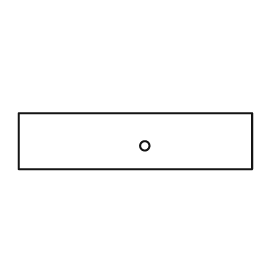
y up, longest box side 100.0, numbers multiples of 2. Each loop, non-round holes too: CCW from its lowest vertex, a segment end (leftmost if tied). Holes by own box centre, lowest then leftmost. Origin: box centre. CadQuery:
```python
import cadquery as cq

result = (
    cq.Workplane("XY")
    .moveTo(-50.0, -12.0)
    .lineTo(50.0, -12.0)
    .lineTo(50.0, 12.0)
    .lineTo(-50.0, 12.0)
    .close()
    .moveTo(4.0, -2.0)
    .circle(2.0)
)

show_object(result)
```